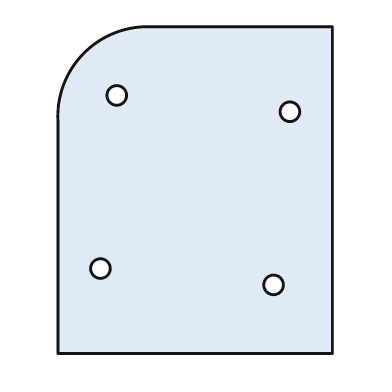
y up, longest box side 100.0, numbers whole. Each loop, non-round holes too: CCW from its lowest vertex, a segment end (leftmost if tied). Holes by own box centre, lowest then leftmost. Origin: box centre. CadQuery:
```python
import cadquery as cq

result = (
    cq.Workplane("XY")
    .moveTo(-42.0, -50.0)
    .lineTo(42.0, -50.0)
    .lineTo(42.0, 50.0)
    .lineTo(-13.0, 50.0)
    .threePointArc((-34.0, 42.0), (-42.0, 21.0))
    .close()
    .moveTo(24.0, -29.0)
    .circle(3.0)
    .moveTo(-29.0, -24.0)
    .circle(3.0)
    .moveTo(29.0, 24.0)
    .circle(3.0)
    .moveTo(-24.0, 29.0)
    .circle(3.0)
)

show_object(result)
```